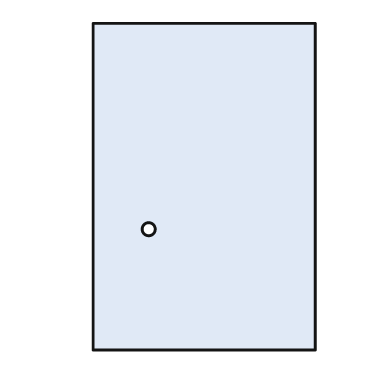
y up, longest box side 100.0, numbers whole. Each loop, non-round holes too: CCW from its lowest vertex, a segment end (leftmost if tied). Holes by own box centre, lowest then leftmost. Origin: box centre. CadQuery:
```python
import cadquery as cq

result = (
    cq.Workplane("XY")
    .moveTo(-34.0, -50.0)
    .lineTo(34.0, -50.0)
    .lineTo(34.0, 50.0)
    .lineTo(-34.0, 50.0)
    .close()
    .moveTo(-17.0, -13.0)
    .circle(2.0)
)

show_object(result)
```